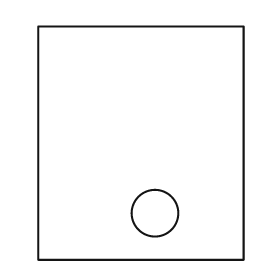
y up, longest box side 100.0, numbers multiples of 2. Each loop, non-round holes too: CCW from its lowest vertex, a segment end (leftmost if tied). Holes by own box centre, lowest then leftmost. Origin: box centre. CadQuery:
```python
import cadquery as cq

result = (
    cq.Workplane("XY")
    .moveTo(-44.0, -50.0)
    .lineTo(44.0, -50.0)
    .lineTo(44.0, 50.0)
    .lineTo(-44.0, 50.0)
    .close()
    .moveTo(6.0, -30.0)
    .circle(10.0)
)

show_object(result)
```